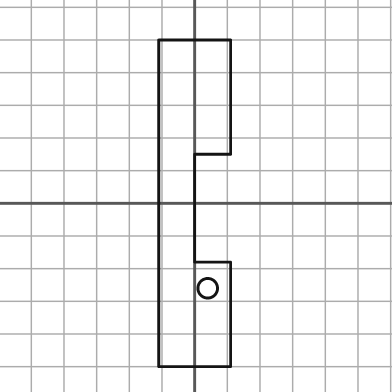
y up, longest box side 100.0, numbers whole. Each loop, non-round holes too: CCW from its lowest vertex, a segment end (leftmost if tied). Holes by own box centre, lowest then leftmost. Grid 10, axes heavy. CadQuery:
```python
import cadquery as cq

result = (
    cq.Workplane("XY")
    .moveTo(-11.0, -50.0)
    .lineTo(11.0, -50.0)
    .lineTo(11.0, -18.0)
    .lineTo(0.0, -18.0)
    .lineTo(0.0, 15.0)
    .lineTo(11.0, 15.0)
    .lineTo(11.0, 50.0)
    .lineTo(-11.0, 50.0)
    .close()
    .moveTo(4.0, -26.0)
    .circle(3.0)
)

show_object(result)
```